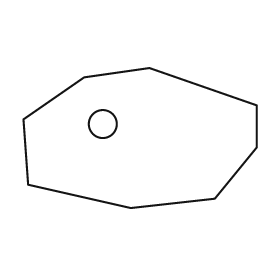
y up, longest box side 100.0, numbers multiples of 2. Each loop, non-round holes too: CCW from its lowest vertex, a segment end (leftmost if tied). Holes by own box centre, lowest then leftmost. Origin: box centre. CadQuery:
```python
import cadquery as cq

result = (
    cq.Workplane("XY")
    .moveTo(-4.0, -30.0)
    .lineTo(32.0, -26.0)
    .lineTo(50.0, -4.0)
    .lineTo(50.0, 14.0)
    .lineTo(4.0, 30.0)
    .lineTo(-24.0, 26.0)
    .lineTo(-50.0, 8.0)
    .lineTo(-48.0, -20.0)
    .close()
    .moveTo(-16.0, 6.0)
    .circle(6.0)
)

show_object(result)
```